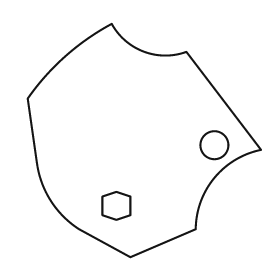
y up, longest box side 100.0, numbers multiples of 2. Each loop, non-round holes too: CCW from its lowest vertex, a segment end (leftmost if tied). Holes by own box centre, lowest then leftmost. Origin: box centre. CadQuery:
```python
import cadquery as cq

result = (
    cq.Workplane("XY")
    .moveTo(-6.0, -50.0)
    .lineTo(22.0, -38.0)
    .threePointArc((30.0, -16.0), (50.0, -4.0))
    .lineTo(18.0, 38.0)
    .threePointArc((0.0, 38.0), (-14.0, 50.0))
    .threePointArc((-34.0, 36.0), (-50.0, 18.0))
    .lineTo(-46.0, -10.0)
    .threePointArc((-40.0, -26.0), (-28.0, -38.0))
    .close()
    .moveTo(-12.0, -34.0)
    .lineTo(-6.0, -32.0)
    .lineTo(-6.0, -24.0)
    .lineTo(-12.0, -22.0)
    .lineTo(-18.0, -24.0)
    .lineTo(-18.0, -32.0)
    .close()
    .moveTo(30.0, -2.0)
    .circle(6.0)
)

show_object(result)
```